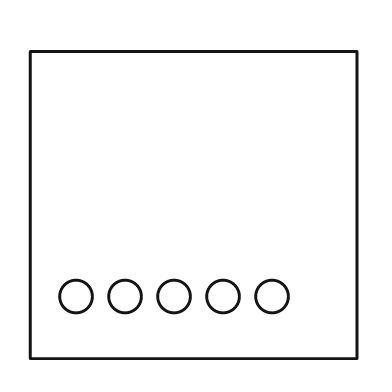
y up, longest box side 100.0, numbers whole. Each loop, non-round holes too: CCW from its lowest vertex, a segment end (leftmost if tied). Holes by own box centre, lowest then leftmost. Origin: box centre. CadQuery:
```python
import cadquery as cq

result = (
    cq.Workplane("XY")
    .moveTo(-50.0, -47.0)
    .lineTo(50.0, -47.0)
    .lineTo(50.0, 47.0)
    .lineTo(-50.0, 47.0)
    .close()
    .moveTo(-36.0, -28.0)
    .circle(5.0)
    .moveTo(-21.0, -28.0)
    .circle(5.0)
    .moveTo(-6.0, -28.0)
    .circle(5.0)
    .moveTo(9.0, -28.0)
    .circle(5.0)
    .moveTo(24.0, -28.0)
    .circle(5.0)
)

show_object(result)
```